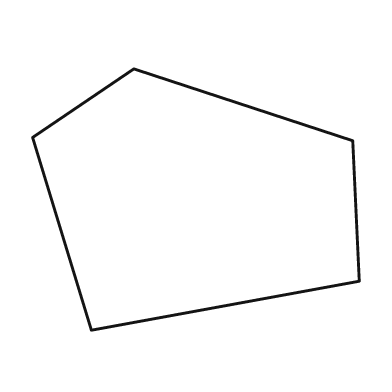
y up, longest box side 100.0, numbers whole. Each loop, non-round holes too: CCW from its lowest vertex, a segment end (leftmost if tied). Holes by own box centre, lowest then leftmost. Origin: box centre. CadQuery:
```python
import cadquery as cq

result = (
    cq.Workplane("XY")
    .moveTo(-32.0, -40.0)
    .lineTo(50.0, -25.0)
    .lineTo(48.0, 18.0)
    .lineTo(-19.0, 40.0)
    .lineTo(-50.0, 19.0)
    .close()
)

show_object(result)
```